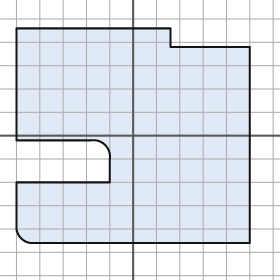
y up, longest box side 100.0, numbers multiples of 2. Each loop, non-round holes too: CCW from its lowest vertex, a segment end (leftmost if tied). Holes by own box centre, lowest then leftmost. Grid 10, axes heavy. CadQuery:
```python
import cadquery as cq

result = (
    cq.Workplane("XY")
    .moveTo(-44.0, -46.0)
    .lineTo(50.0, -46.0)
    .lineTo(50.0, 38.0)
    .lineTo(16.0, 38.0)
    .lineTo(16.0, 46.0)
    .lineTo(-50.0, 46.0)
    .lineTo(-50.0, -2.0)
    .lineTo(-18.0, -2.0)
    .threePointArc((-12.0, -4.0), (-10.0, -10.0))
    .lineTo(-10.0, -20.0)
    .lineTo(-50.0, -20.0)
    .lineTo(-50.0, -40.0)
    .threePointArc((-48.0, -44.0), (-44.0, -46.0))
    .close()
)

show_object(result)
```